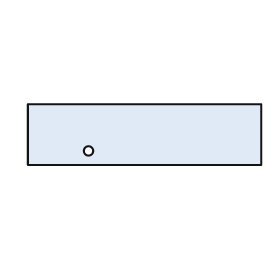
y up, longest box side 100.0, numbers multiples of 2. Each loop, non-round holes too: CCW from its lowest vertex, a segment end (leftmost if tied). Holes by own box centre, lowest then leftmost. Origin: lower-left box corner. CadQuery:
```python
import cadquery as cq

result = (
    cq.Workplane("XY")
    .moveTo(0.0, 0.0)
    .lineTo(100.0, 0.0)
    .lineTo(100.0, 26.0)
    .lineTo(0.0, 26.0)
    .close()
    .moveTo(26.0, 6.0)
    .circle(2.0)
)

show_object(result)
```